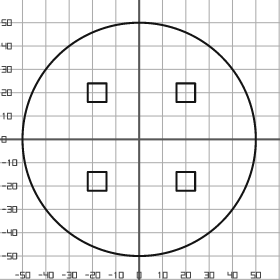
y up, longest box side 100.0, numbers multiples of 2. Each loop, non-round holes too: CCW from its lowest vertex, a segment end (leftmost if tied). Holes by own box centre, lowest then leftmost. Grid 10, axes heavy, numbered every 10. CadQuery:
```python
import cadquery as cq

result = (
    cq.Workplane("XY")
    .moveTo(0.0, 0.0)
    .circle(50.0)
    .moveTo(-22.0, -22.0)
    .lineTo(-14.0, -22.0)
    .lineTo(-14.0, -14.0)
    .lineTo(-22.0, -14.0)
    .close()
    .moveTo(16.0, -22.0)
    .lineTo(24.0, -22.0)
    .lineTo(24.0, -14.0)
    .lineTo(16.0, -14.0)
    .close()
    .moveTo(-22.0, 16.0)
    .lineTo(-14.0, 16.0)
    .lineTo(-14.0, 24.0)
    .lineTo(-22.0, 24.0)
    .close()
    .moveTo(16.0, 16.0)
    .lineTo(24.0, 16.0)
    .lineTo(24.0, 24.0)
    .lineTo(16.0, 24.0)
    .close()
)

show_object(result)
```